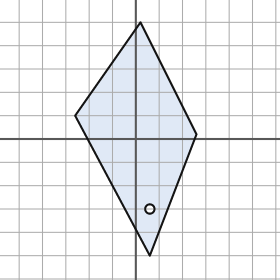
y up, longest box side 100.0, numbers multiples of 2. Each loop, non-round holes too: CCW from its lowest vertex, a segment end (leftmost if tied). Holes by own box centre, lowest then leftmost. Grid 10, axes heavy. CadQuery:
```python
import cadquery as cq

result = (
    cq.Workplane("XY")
    .moveTo(6.0, -50.0)
    .lineTo(26.0, 2.0)
    .lineTo(2.0, 50.0)
    .lineTo(-26.0, 10.0)
    .close()
    .moveTo(6.0, -30.0)
    .circle(2.0)
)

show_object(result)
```